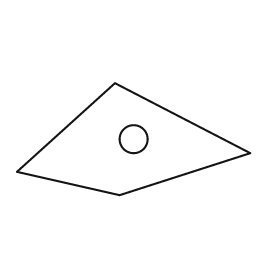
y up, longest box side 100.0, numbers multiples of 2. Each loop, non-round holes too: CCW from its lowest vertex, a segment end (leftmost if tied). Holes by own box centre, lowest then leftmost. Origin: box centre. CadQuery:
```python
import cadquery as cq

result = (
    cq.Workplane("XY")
    .moveTo(-6.0, -24.0)
    .lineTo(50.0, -6.0)
    .lineTo(-8.0, 24.0)
    .lineTo(-50.0, -14.0)
    .close()
    .moveTo(0.0, 0.0)
    .circle(6.0)
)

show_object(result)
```